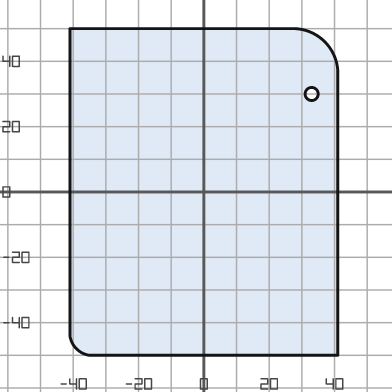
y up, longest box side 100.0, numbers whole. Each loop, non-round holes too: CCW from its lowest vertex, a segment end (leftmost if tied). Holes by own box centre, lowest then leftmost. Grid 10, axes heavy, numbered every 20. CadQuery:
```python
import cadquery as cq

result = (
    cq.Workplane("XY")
    .moveTo(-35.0, -50.0)
    .lineTo(41.0, -50.0)
    .lineTo(41.0, 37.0)
    .threePointArc((37.0, 46.0), (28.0, 50.0))
    .lineTo(-41.0, 50.0)
    .lineTo(-41.0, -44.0)
    .threePointArc((-39.0, -48.0), (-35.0, -50.0))
    .close()
    .moveTo(33.0, 30.0)
    .circle(2.0)
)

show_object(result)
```